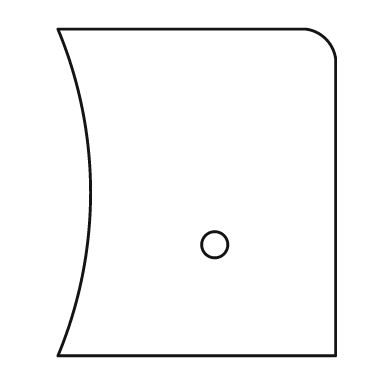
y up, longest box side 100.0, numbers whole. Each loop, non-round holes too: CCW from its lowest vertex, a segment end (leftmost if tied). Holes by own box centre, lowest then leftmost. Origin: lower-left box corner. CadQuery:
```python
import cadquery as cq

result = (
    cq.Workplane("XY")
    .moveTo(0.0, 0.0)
    .lineTo(85.0, 0.0)
    .lineTo(85.0, 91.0)
    .threePointArc((82.0, 97.0), (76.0, 100.0))
    .lineTo(0.0, 100.0)
    .threePointArc((10.0, 50.0), (0.0, 0.0))
    .close()
    .moveTo(48.0, 34.0)
    .circle(4.0)
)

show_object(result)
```